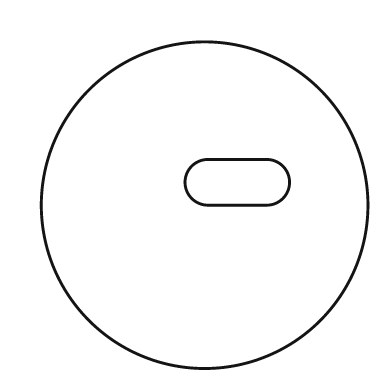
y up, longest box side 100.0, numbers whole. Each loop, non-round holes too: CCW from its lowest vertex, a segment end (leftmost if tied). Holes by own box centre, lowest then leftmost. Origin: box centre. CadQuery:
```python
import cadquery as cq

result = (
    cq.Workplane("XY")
    .moveTo(0.0, 0.0)
    .circle(50.0)
    .moveTo(1.0, 0.0)
    .lineTo(19.0, 0.0)
    .threePointArc((26.0, 7.0), (19.0, 14.0))
    .lineTo(1.0, 14.0)
    .threePointArc((-6.0, 7.0), (1.0, 0.0))
    .close()
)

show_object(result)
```